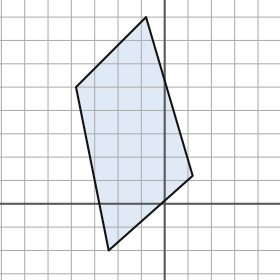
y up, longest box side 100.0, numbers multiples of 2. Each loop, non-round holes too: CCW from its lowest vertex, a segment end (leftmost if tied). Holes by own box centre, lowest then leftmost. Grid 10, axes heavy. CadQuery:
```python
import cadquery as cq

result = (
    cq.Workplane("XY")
    .moveTo(-24.0, -20.0)
    .lineTo(12.0, 12.0)
    .lineTo(-8.0, 80.0)
    .lineTo(-38.0, 50.0)
    .close()
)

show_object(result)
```